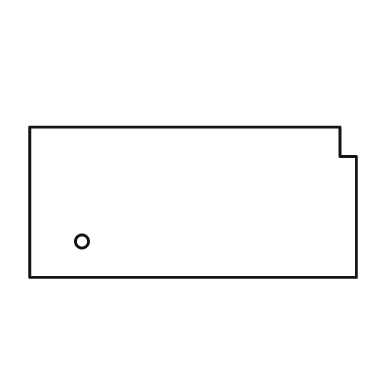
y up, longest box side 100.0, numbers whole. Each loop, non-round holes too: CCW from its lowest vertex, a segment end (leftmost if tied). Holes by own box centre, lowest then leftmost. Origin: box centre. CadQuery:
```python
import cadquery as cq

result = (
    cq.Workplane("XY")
    .moveTo(-50.0, -23.0)
    .lineTo(50.0, -23.0)
    .lineTo(50.0, 14.0)
    .lineTo(45.0, 14.0)
    .lineTo(45.0, 23.0)
    .lineTo(-50.0, 23.0)
    .close()
    .moveTo(-34.0, -12.0)
    .circle(2.0)
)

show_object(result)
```